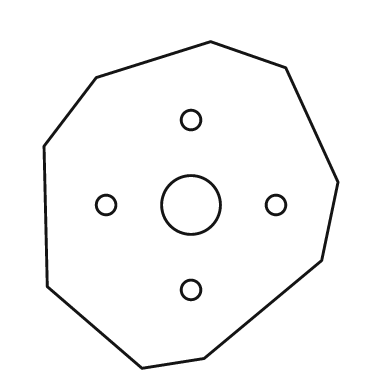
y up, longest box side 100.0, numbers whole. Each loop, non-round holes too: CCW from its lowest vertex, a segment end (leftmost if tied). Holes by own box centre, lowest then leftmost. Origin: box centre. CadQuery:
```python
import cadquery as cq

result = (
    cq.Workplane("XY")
    .moveTo(-15.0, -50.0)
    .lineTo(4.0, -47.0)
    .lineTo(40.0, -17.0)
    .lineTo(45.0, 7.0)
    .lineTo(29.0, 42.0)
    .lineTo(6.0, 50.0)
    .lineTo(-29.0, 39.0)
    .lineTo(-45.0, 18.0)
    .lineTo(-44.0, -25.0)
    .close()
    .moveTo(0.0, -26.0)
    .circle(3.0)
    .moveTo(-26.0, 0.0)
    .circle(3.0)
    .moveTo(0.0, 0.0)
    .circle(9.0)
    .moveTo(26.0, 0.0)
    .circle(3.0)
    .moveTo(0.0, 26.0)
    .circle(3.0)
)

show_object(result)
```